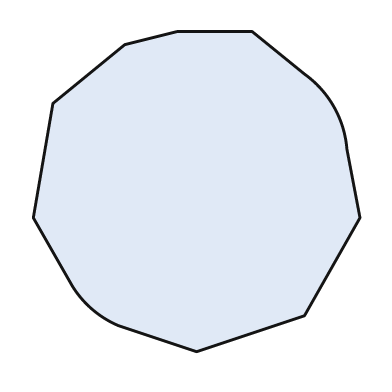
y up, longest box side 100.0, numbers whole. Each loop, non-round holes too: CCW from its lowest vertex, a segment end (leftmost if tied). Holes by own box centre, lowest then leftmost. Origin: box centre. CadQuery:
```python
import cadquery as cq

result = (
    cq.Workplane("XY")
    .moveTo(0.0, -49.0)
    .lineTo(33.0, -38.0)
    .lineTo(50.0, -8.0)
    .lineTo(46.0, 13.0)
    .threePointArc((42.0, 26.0), (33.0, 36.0))
    .lineTo(17.0, 49.0)
    .lineTo(-6.0, 49.0)
    .lineTo(-22.0, 45.0)
    .lineTo(-44.0, 27.0)
    .lineTo(-50.0, -8.0)
    .lineTo(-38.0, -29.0)
    .threePointArc((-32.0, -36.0), (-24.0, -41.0))
    .close()
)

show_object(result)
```